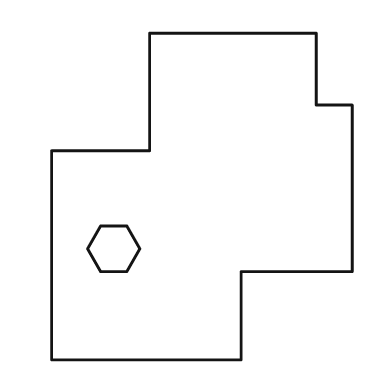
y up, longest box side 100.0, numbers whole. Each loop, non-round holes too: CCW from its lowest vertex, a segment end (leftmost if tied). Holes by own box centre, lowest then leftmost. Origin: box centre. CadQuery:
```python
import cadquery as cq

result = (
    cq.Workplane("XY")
    .moveTo(-46.0, -50.0)
    .lineTo(12.0, -50.0)
    .lineTo(12.0, -23.0)
    .lineTo(46.0, -23.0)
    .lineTo(46.0, 28.0)
    .lineTo(35.0, 28.0)
    .lineTo(35.0, 50.0)
    .lineTo(-16.0, 50.0)
    .lineTo(-16.0, 14.0)
    .lineTo(-46.0, 14.0)
    .close()
    .moveTo(-31.0, -23.0)
    .lineTo(-23.0, -23.0)
    .lineTo(-19.0, -16.0)
    .lineTo(-23.0, -9.0)
    .lineTo(-31.0, -9.0)
    .lineTo(-35.0, -16.0)
    .close()
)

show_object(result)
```